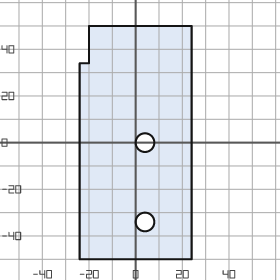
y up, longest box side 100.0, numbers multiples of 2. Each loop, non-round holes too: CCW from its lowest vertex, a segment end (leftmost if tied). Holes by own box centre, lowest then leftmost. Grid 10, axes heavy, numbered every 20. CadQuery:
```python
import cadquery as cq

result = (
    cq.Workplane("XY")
    .moveTo(-24.0, -50.0)
    .lineTo(24.0, -50.0)
    .lineTo(24.0, 50.0)
    .lineTo(-20.0, 50.0)
    .lineTo(-20.0, 34.0)
    .lineTo(-24.0, 34.0)
    .close()
    .moveTo(4.0, -34.0)
    .circle(4.0)
    .moveTo(4.0, 0.0)
    .circle(4.0)
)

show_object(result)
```